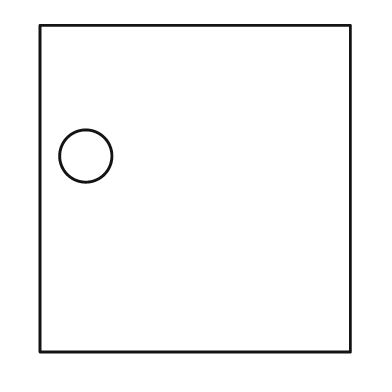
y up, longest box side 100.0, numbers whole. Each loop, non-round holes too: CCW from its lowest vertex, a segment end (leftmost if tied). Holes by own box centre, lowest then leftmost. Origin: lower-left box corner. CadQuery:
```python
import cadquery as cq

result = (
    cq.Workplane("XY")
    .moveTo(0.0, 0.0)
    .lineTo(95.0, 0.0)
    .lineTo(95.0, 100.0)
    .lineTo(0.0, 100.0)
    .close()
    .moveTo(14.0, 60.0)
    .circle(8.0)
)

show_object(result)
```